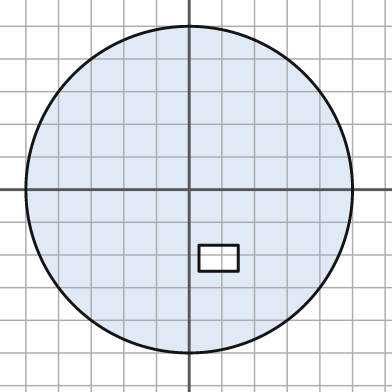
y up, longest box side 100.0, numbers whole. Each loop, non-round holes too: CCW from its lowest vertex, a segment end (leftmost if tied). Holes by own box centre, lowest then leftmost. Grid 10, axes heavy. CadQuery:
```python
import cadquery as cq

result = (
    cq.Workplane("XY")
    .moveTo(0.0, 0.0)
    .circle(50.0)
    .moveTo(3.0, -25.0)
    .lineTo(15.0, -25.0)
    .lineTo(15.0, -17.0)
    .lineTo(3.0, -17.0)
    .close()
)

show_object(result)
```